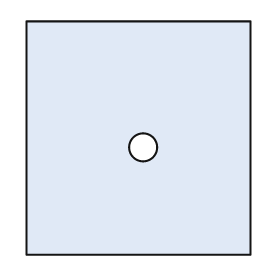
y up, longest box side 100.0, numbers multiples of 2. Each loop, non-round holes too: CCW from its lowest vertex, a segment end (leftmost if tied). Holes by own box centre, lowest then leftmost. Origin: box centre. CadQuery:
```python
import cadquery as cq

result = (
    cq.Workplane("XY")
    .moveTo(-48.0, -50.0)
    .lineTo(48.0, -50.0)
    .lineTo(48.0, 50.0)
    .lineTo(-48.0, 50.0)
    .close()
    .moveTo(2.0, -4.0)
    .circle(6.0)
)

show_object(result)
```